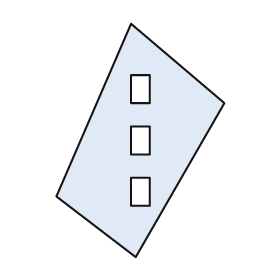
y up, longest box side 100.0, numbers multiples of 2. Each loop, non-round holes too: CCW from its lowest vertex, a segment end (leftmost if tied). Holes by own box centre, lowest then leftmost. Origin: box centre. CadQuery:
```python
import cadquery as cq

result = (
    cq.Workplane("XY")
    .moveTo(-2.0, -50.0)
    .lineTo(36.0, 16.0)
    .lineTo(-4.0, 50.0)
    .lineTo(-36.0, -24.0)
    .close()
    .moveTo(-4.0, -28.0)
    .lineTo(4.0, -28.0)
    .lineTo(4.0, -16.0)
    .lineTo(-4.0, -16.0)
    .close()
    .moveTo(-4.0, -6.0)
    .lineTo(4.0, -6.0)
    .lineTo(4.0, 6.0)
    .lineTo(-4.0, 6.0)
    .close()
    .moveTo(-4.0, 16.0)
    .lineTo(4.0, 16.0)
    .lineTo(4.0, 28.0)
    .lineTo(-4.0, 28.0)
    .close()
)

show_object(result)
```